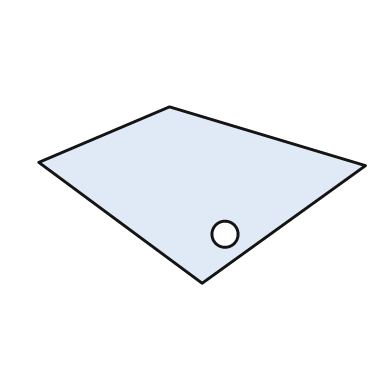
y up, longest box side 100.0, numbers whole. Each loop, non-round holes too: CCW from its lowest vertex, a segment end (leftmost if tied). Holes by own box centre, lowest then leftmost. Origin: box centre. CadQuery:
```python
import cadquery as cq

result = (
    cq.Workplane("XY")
    .moveTo(0.0, -27.0)
    .lineTo(50.0, 9.0)
    .lineTo(-10.0, 27.0)
    .lineTo(-50.0, 10.0)
    .close()
    .moveTo(7.0, -12.0)
    .circle(4.0)
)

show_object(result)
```